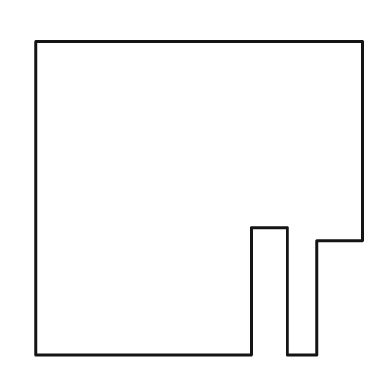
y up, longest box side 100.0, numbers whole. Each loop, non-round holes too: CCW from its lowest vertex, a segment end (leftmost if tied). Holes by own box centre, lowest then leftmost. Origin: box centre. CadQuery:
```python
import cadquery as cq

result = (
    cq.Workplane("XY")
    .moveTo(-50.0, -48.0)
    .lineTo(16.0, -48.0)
    .lineTo(16.0, -9.0)
    .lineTo(27.0, -9.0)
    .lineTo(27.0, -48.0)
    .lineTo(36.0, -48.0)
    .lineTo(36.0, -13.0)
    .lineTo(50.0, -13.0)
    .lineTo(50.0, 48.0)
    .lineTo(-50.0, 48.0)
    .close()
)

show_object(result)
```